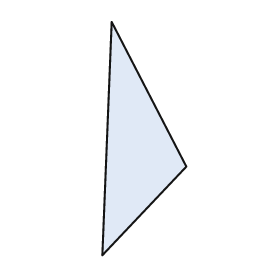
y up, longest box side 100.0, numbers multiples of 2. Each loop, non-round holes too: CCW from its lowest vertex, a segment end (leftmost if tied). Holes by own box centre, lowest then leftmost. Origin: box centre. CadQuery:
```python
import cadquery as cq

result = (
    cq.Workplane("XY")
    .moveTo(-18.0, -50.0)
    .lineTo(18.0, -12.0)
    .lineTo(-14.0, 50.0)
    .close()
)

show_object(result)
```